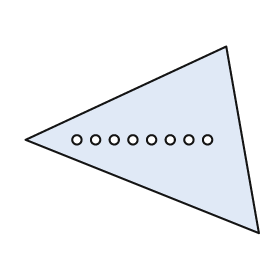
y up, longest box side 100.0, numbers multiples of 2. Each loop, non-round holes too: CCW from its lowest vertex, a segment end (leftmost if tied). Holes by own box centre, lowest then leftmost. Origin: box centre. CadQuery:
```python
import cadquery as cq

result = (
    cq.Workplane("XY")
    .moveTo(50.0, -40.0)
    .lineTo(36.0, 40.0)
    .lineTo(-50.0, 0.0)
    .close()
    .moveTo(-28.0, 0.0)
    .circle(2.0)
    .moveTo(-20.0, 0.0)
    .circle(2.0)
    .moveTo(-12.0, 0.0)
    .circle(2.0)
    .moveTo(-4.0, 0.0)
    .circle(2.0)
    .moveTo(4.0, 0.0)
    .circle(2.0)
    .moveTo(12.0, 0.0)
    .circle(2.0)
    .moveTo(20.0, 0.0)
    .circle(2.0)
    .moveTo(28.0, 0.0)
    .circle(2.0)
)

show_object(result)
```